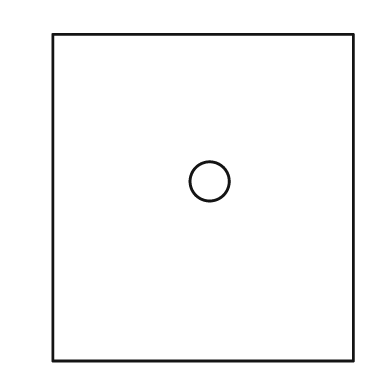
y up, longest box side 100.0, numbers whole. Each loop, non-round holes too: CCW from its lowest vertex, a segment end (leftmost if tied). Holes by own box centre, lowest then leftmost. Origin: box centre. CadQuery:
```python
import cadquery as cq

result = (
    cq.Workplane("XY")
    .moveTo(-46.0, -50.0)
    .lineTo(46.0, -50.0)
    .lineTo(46.0, 50.0)
    .lineTo(-46.0, 50.0)
    .close()
    .moveTo(2.0, 5.0)
    .circle(6.0)
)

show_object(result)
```